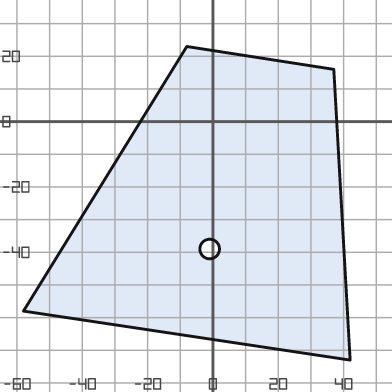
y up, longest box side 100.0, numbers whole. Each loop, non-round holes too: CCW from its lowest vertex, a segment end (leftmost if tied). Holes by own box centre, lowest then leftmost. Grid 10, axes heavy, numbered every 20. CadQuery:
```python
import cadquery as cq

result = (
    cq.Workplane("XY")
    .moveTo(42.0, -73.0)
    .lineTo(37.0, 16.0)
    .lineTo(-8.0, 23.0)
    .lineTo(-58.0, -58.0)
    .close()
    .moveTo(-1.0, -39.0)
    .circle(3.0)
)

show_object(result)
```